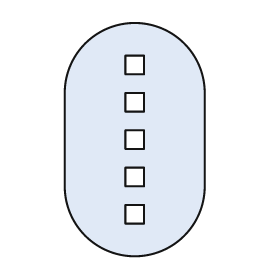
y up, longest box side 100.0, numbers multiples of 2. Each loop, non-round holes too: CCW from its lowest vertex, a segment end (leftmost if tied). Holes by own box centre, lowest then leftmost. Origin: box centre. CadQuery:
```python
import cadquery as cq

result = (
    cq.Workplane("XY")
    .moveTo(-30.0, -20.0)
    .threePointArc((0.0, -50.0), (30.0, -20.0))
    .lineTo(30.0, 20.0)
    .threePointArc((0.0, 50.0), (-30.0, 20.0))
    .close()
    .moveTo(-4.0, -36.0)
    .lineTo(4.0, -36.0)
    .lineTo(4.0, -28.0)
    .lineTo(-4.0, -28.0)
    .close()
    .moveTo(-4.0, -20.0)
    .lineTo(4.0, -20.0)
    .lineTo(4.0, -12.0)
    .lineTo(-4.0, -12.0)
    .close()
    .moveTo(-4.0, -4.0)
    .lineTo(4.0, -4.0)
    .lineTo(4.0, 4.0)
    .lineTo(-4.0, 4.0)
    .close()
    .moveTo(-4.0, 12.0)
    .lineTo(4.0, 12.0)
    .lineTo(4.0, 20.0)
    .lineTo(-4.0, 20.0)
    .close()
    .moveTo(-4.0, 28.0)
    .lineTo(4.0, 28.0)
    .lineTo(4.0, 36.0)
    .lineTo(-4.0, 36.0)
    .close()
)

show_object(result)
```